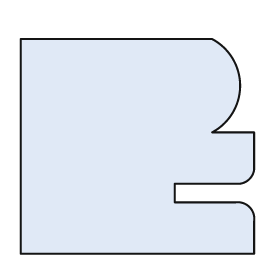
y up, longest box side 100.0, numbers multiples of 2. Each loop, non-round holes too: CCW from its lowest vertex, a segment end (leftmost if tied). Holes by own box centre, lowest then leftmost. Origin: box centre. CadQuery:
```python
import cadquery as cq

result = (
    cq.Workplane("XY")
    .moveTo(-50.0, -46.0)
    .lineTo(50.0, -46.0)
    .lineTo(50.0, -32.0)
    .threePointArc((48.0, -26.0), (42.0, -24.0))
    .lineTo(16.0, -24.0)
    .lineTo(16.0, -16.0)
    .lineTo(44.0, -16.0)
    .threePointArc((48.0, -14.0), (50.0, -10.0))
    .lineTo(50.0, 6.0)
    .lineTo(32.0, 6.0)
    .threePointArc((44.0, 26.0), (32.0, 46.0))
    .lineTo(-50.0, 46.0)
    .close()
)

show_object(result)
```